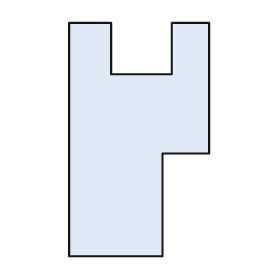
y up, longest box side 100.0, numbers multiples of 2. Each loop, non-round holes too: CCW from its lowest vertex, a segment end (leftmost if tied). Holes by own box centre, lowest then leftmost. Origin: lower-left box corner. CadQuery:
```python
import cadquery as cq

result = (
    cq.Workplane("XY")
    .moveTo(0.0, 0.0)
    .lineTo(40.0, 0.0)
    .lineTo(40.0, 44.0)
    .lineTo(60.0, 44.0)
    .lineTo(60.0, 100.0)
    .lineTo(44.0, 100.0)
    .lineTo(44.0, 78.0)
    .lineTo(18.0, 78.0)
    .lineTo(18.0, 100.0)
    .lineTo(0.0, 100.0)
    .close()
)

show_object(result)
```